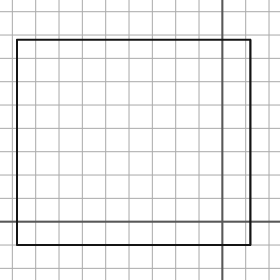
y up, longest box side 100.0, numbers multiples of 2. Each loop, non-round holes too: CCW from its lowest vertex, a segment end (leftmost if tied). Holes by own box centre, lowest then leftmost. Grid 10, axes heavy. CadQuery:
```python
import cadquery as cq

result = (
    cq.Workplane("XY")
    .moveTo(-88.0, -10.0)
    .lineTo(12.0, -10.0)
    .lineTo(12.0, 78.0)
    .lineTo(-88.0, 78.0)
    .close()
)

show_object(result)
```